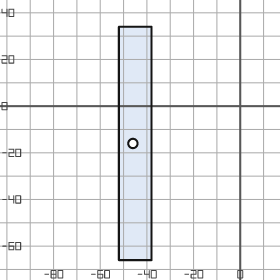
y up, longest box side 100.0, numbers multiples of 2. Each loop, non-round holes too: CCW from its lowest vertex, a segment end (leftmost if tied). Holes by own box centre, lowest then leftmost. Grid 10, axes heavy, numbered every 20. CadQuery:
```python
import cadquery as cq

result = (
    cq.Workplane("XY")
    .moveTo(-52.0, -66.0)
    .lineTo(-38.0, -66.0)
    .lineTo(-38.0, 34.0)
    .lineTo(-52.0, 34.0)
    .close()
    .moveTo(-46.0, -16.0)
    .circle(2.0)
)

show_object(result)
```